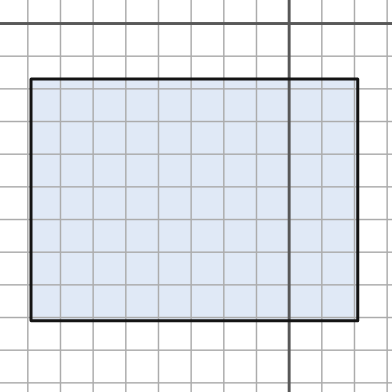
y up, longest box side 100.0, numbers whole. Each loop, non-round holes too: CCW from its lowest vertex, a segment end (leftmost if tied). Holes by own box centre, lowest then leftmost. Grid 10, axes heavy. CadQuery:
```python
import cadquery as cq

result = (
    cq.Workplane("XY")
    .moveTo(-79.0, -91.0)
    .lineTo(21.0, -91.0)
    .lineTo(21.0, -17.0)
    .lineTo(-79.0, -17.0)
    .close()
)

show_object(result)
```